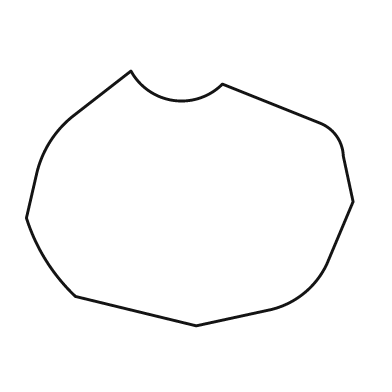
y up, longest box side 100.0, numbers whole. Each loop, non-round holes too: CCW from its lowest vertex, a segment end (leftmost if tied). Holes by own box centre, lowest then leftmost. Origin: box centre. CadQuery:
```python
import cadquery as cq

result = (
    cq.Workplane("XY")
    .moveTo(2.0, -39.0)
    .lineTo(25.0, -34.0)
    .threePointArc((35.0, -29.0), (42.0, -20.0))
    .lineTo(50.0, -1.0)
    .lineTo(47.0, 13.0)
    .threePointArc((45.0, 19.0), (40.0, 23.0))
    .lineTo(10.0, 35.0)
    .threePointArc((-5.0, 30.0), (-18.0, 39.0))
    .lineTo(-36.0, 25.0)
    .threePointArc((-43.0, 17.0), (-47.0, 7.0))
    .lineTo(-50.0, -6.0)
    .threePointArc((-44.0, -19.0), (-35.0, -30.0))
    .close()
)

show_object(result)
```